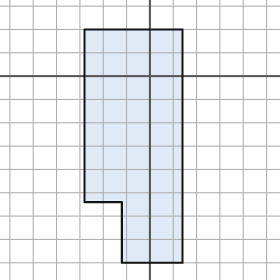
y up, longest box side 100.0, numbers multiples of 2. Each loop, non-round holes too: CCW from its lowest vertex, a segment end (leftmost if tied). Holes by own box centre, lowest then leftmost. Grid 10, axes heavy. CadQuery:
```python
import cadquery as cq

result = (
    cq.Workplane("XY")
    .moveTo(-12.0, -80.0)
    .lineTo(14.0, -80.0)
    .lineTo(14.0, 20.0)
    .lineTo(-28.0, 20.0)
    .lineTo(-28.0, -54.0)
    .lineTo(-12.0, -54.0)
    .close()
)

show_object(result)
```